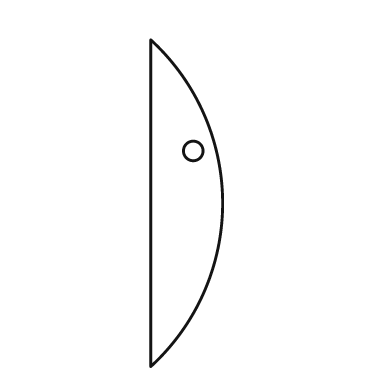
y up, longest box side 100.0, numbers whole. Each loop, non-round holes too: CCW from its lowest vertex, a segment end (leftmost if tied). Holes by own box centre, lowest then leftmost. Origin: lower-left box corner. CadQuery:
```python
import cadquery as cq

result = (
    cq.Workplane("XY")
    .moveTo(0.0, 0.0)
    .threePointArc((22.0, 50.0), (0.0, 100.0))
    .close()
    .moveTo(13.0, 66.0)
    .circle(3.0)
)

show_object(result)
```